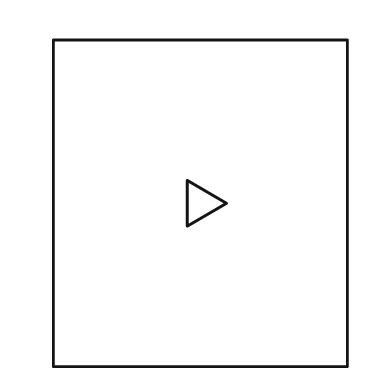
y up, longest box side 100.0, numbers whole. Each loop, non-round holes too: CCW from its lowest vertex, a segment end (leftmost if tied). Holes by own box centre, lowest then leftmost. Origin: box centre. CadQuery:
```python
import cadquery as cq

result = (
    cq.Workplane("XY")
    .moveTo(-45.0, -50.0)
    .lineTo(45.0, -50.0)
    .lineTo(45.0, 50.0)
    .lineTo(-45.0, 50.0)
    .close()
    .moveTo(-4.0, -7.0)
    .lineTo(8.0, 0.0)
    .lineTo(-4.0, 7.0)
    .close()
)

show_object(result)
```